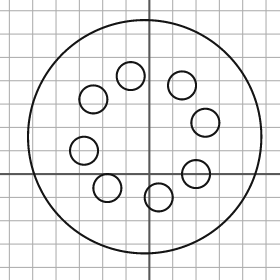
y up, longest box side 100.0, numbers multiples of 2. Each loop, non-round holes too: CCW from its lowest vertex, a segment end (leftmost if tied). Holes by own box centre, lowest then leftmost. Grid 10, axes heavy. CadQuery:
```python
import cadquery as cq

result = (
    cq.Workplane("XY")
    .moveTo(-2.0, 16.0)
    .circle(50.0)
    .moveTo(4.0, -10.0)
    .circle(6.0)
    .moveTo(-18.0, -6.0)
    .circle(6.0)
    .moveTo(20.0, 0.0)
    .circle(6.0)
    .moveTo(-28.0, 10.0)
    .circle(6.0)
    .moveTo(24.0, 22.0)
    .circle(6.0)
    .moveTo(-24.0, 32.0)
    .circle(6.0)
    .moveTo(14.0, 38.0)
    .circle(6.0)
    .moveTo(-8.0, 42.0)
    .circle(6.0)
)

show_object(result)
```